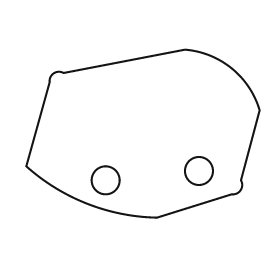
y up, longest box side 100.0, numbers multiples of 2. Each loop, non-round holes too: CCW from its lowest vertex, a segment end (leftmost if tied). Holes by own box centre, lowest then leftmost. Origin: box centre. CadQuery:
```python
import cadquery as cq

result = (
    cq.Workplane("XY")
    .moveTo(6.0, -36.0)
    .lineTo(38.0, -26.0)
    .threePointArc((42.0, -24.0), (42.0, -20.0))
    .lineTo(50.0, 10.0)
    .threePointArc((38.0, 28.0), (18.0, 36.0))
    .lineTo(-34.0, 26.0)
    .threePointArc((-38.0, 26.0), (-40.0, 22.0))
    .lineTo(-50.0, -14.0)
    .threePointArc((-24.0, -30.0), (6.0, -36.0))
    .close()
    .moveTo(-16.0, -20.0)
    .circle(6.0)
    .moveTo(24.0, -16.0)
    .circle(6.0)
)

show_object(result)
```